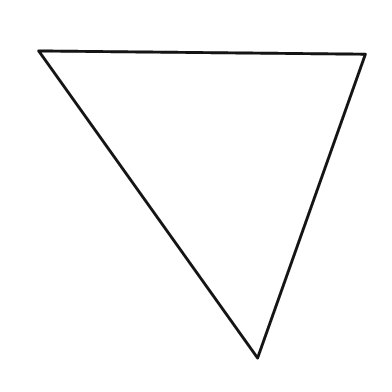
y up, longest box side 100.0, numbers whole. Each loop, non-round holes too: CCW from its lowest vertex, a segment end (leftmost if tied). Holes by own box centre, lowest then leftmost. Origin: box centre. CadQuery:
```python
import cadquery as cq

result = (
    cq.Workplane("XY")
    .moveTo(17.0, -47.0)
    .lineTo(50.0, 46.0)
    .lineTo(-50.0, 47.0)
    .close()
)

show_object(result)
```